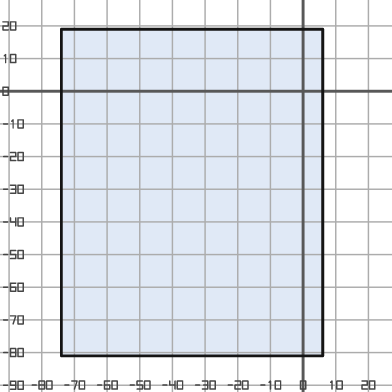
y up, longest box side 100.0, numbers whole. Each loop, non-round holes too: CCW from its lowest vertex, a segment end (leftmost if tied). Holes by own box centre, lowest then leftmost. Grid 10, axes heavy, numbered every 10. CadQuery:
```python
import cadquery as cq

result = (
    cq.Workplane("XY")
    .moveTo(-74.0, -81.0)
    .lineTo(6.0, -81.0)
    .lineTo(6.0, 19.0)
    .lineTo(-74.0, 19.0)
    .close()
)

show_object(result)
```